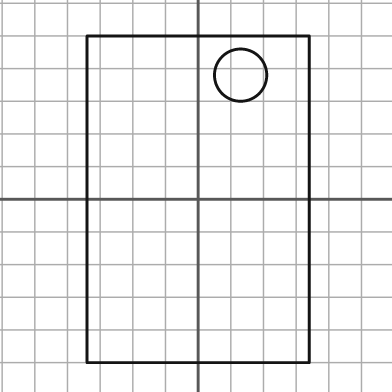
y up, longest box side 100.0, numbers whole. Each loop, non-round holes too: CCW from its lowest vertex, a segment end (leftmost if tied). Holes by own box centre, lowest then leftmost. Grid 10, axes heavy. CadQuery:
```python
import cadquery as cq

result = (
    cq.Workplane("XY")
    .moveTo(-34.0, -50.0)
    .lineTo(34.0, -50.0)
    .lineTo(34.0, 50.0)
    .lineTo(-34.0, 50.0)
    .close()
    .moveTo(13.0, 38.0)
    .circle(8.0)
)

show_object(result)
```